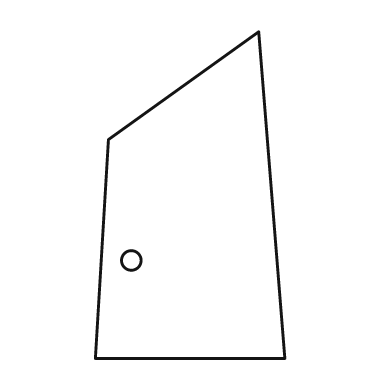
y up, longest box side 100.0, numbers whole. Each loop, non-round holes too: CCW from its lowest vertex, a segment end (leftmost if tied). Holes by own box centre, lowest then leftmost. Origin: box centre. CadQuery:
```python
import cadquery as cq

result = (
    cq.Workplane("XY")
    .moveTo(-29.0, -50.0)
    .lineTo(29.0, -50.0)
    .lineTo(21.0, 50.0)
    .lineTo(-25.0, 17.0)
    .close()
    .moveTo(-18.0, -20.0)
    .circle(3.0)
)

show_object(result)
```